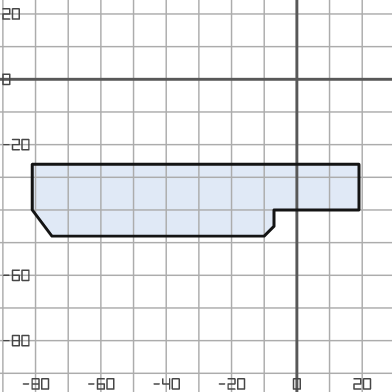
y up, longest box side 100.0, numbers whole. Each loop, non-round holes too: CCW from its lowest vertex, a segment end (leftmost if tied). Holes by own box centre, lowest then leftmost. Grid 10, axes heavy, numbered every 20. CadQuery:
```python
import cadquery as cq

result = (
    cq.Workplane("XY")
    .moveTo(-75.0, -48.0)
    .lineTo(-10.0, -48.0)
    .lineTo(-7.0, -45.0)
    .lineTo(-7.0, -40.0)
    .lineTo(19.0, -40.0)
    .lineTo(19.0, -26.0)
    .lineTo(-81.0, -26.0)
    .lineTo(-81.0, -40.0)
    .close()
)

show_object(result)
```